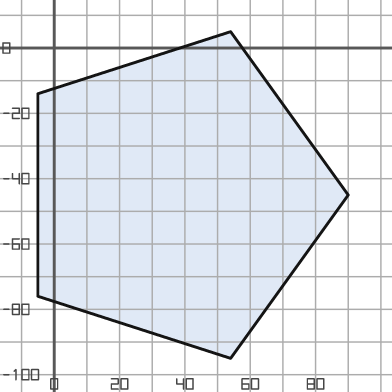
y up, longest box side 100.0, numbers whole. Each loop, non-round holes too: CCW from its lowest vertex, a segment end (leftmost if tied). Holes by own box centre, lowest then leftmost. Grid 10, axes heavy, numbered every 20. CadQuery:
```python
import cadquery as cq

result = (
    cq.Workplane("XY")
    .moveTo(54.0, -95.0)
    .lineTo(90.0, -45.0)
    .lineTo(54.0, 5.0)
    .lineTo(-5.0, -14.0)
    .lineTo(-5.0, -76.0)
    .close()
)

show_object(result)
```